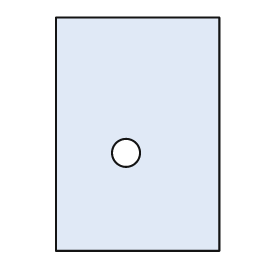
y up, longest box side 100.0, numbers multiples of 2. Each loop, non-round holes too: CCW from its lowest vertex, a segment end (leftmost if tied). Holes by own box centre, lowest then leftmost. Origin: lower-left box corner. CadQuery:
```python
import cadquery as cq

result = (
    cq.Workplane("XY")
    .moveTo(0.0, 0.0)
    .lineTo(70.0, 0.0)
    .lineTo(70.0, 100.0)
    .lineTo(0.0, 100.0)
    .close()
    .moveTo(30.0, 42.0)
    .circle(6.0)
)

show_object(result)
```